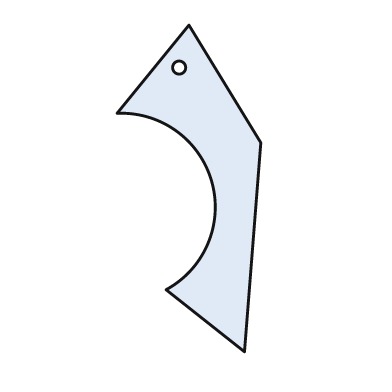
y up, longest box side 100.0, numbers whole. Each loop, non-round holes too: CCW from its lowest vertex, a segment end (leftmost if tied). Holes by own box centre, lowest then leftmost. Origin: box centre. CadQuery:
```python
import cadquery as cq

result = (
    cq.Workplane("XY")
    .moveTo(17.0, -50.0)
    .lineTo(22.0, 14.0)
    .lineTo(0.0, 50.0)
    .lineTo(-22.0, 23.0)
    .threePointArc((7.0, 2.0), (-7.0, -31.0))
    .close()
    .moveTo(-3.0, 37.0)
    .circle(2.0)
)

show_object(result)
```